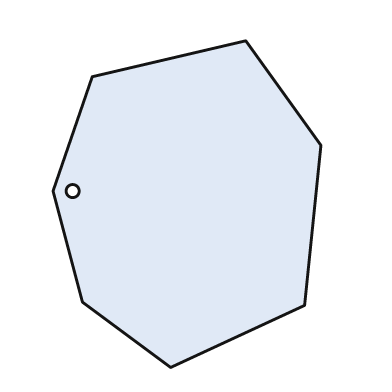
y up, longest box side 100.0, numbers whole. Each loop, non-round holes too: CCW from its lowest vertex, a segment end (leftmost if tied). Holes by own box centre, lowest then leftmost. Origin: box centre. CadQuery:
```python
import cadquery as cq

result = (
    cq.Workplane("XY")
    .moveTo(-5.0, -50.0)
    .lineTo(36.0, -31.0)
    .lineTo(41.0, 18.0)
    .lineTo(18.0, 50.0)
    .lineTo(-29.0, 39.0)
    .lineTo(-41.0, 4.0)
    .lineTo(-32.0, -30.0)
    .close()
    .moveTo(-35.0, 4.0)
    .circle(2.0)
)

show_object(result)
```